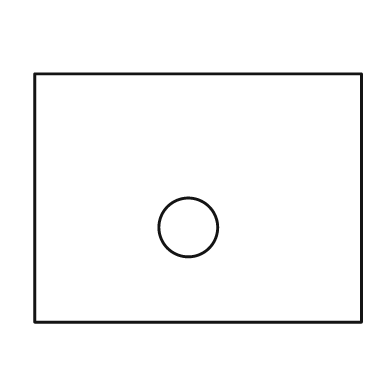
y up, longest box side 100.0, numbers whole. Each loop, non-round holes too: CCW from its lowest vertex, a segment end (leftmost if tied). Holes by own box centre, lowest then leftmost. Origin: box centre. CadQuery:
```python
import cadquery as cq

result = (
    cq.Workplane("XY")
    .moveTo(-50.0, -38.0)
    .lineTo(50.0, -38.0)
    .lineTo(50.0, 38.0)
    .lineTo(-50.0, 38.0)
    .close()
    .moveTo(-3.0, -9.0)
    .circle(9.0)
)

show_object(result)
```